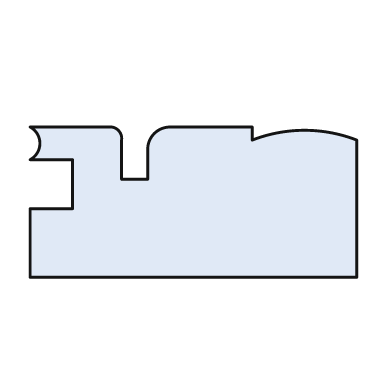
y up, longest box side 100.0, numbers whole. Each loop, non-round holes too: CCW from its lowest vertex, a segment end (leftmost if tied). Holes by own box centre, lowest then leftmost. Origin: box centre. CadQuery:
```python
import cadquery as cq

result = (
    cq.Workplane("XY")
    .moveTo(-50.0, -23.0)
    .lineTo(50.0, -23.0)
    .lineTo(50.0, 19.0)
    .threePointArc((34.0, 22.0), (18.0, 19.0))
    .lineTo(18.0, 23.0)
    .lineTo(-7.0, 23.0)
    .threePointArc((-12.0, 21.0), (-14.0, 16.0))
    .lineTo(-14.0, 7.0)
    .lineTo(-22.0, 7.0)
    .lineTo(-22.0, 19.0)
    .threePointArc((-23.0, 22.0), (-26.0, 23.0))
    .lineTo(-50.0, 23.0)
    .threePointArc((-47.0, 18.0), (-50.0, 13.0))
    .lineTo(-37.0, 13.0)
    .lineTo(-37.0, -2.0)
    .lineTo(-50.0, -2.0)
    .close()
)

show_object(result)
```